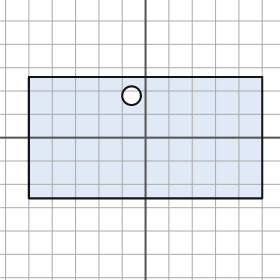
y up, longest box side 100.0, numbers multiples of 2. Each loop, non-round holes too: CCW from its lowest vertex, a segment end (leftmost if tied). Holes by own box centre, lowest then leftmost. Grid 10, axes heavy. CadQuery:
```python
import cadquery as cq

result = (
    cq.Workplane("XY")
    .moveTo(-50.0, -26.0)
    .lineTo(50.0, -26.0)
    .lineTo(50.0, 26.0)
    .lineTo(-50.0, 26.0)
    .close()
    .moveTo(-6.0, 18.0)
    .circle(4.0)
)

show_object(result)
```